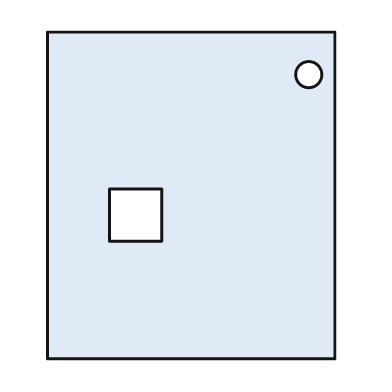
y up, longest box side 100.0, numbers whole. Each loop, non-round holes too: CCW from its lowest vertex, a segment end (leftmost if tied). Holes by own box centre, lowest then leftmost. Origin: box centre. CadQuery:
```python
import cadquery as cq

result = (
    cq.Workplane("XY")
    .moveTo(-44.0, -50.0)
    .lineTo(44.0, -50.0)
    .lineTo(44.0, 50.0)
    .lineTo(-44.0, 50.0)
    .close()
    .moveTo(-25.0, -14.0)
    .lineTo(-9.0, -14.0)
    .lineTo(-9.0, 2.0)
    .lineTo(-25.0, 2.0)
    .close()
    .moveTo(36.0, 37.0)
    .circle(4.0)
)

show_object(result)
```